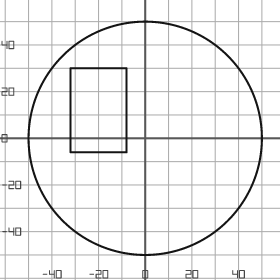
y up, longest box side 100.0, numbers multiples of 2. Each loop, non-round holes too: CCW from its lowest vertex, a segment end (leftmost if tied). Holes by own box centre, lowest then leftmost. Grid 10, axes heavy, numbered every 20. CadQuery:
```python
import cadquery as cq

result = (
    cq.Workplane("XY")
    .moveTo(0.0, 0.0)
    .circle(50.0)
    .moveTo(-32.0, -6.0)
    .lineTo(-8.0, -6.0)
    .lineTo(-8.0, 30.0)
    .lineTo(-32.0, 30.0)
    .close()
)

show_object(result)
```